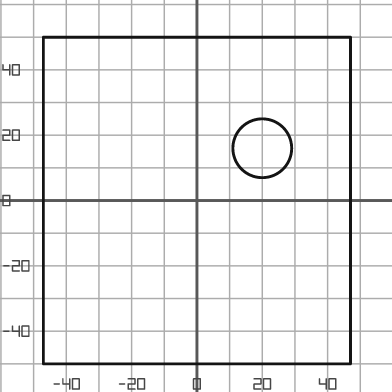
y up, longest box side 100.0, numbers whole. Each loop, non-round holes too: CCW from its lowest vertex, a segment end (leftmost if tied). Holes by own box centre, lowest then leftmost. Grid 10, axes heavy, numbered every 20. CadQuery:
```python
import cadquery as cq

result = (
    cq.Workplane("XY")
    .moveTo(-47.0, -50.0)
    .lineTo(47.0, -50.0)
    .lineTo(47.0, 50.0)
    .lineTo(-47.0, 50.0)
    .close()
    .moveTo(20.0, 16.0)
    .circle(9.0)
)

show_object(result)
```